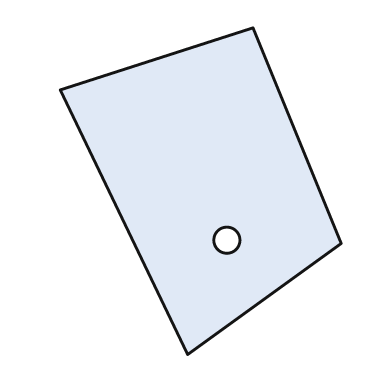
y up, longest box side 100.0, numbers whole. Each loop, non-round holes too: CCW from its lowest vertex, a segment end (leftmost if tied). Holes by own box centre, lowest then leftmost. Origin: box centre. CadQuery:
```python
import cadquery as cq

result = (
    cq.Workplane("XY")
    .moveTo(-4.0, -50.0)
    .lineTo(43.0, -16.0)
    .lineTo(16.0, 50.0)
    .lineTo(-43.0, 31.0)
    .close()
    .moveTo(8.0, -15.0)
    .circle(4.0)
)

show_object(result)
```